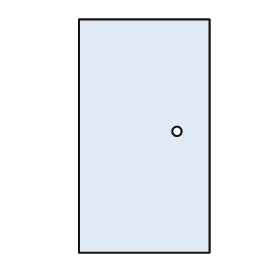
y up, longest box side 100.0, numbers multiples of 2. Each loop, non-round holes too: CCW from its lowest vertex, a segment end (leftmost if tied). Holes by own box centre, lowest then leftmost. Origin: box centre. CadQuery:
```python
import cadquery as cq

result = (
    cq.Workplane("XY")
    .moveTo(-28.0, -50.0)
    .lineTo(28.0, -50.0)
    .lineTo(28.0, 50.0)
    .lineTo(-28.0, 50.0)
    .close()
    .moveTo(14.0, 2.0)
    .circle(2.0)
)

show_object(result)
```